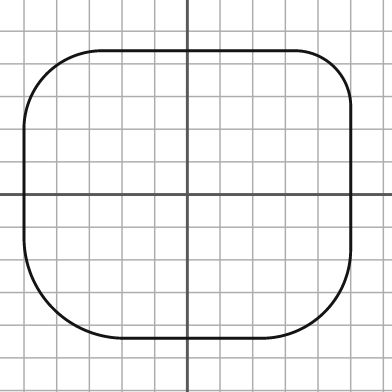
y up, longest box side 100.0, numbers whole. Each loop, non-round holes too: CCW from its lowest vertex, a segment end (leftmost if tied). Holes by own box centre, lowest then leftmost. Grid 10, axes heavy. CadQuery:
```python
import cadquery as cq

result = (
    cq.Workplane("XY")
    .moveTo(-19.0, -44.0)
    .lineTo(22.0, -44.0)
    .threePointArc((42.0, -36.0), (50.0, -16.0))
    .lineTo(50.0, 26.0)
    .threePointArc((45.0, 39.0), (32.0, 44.0))
    .lineTo(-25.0, 44.0)
    .threePointArc((-43.0, 37.0), (-50.0, 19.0))
    .lineTo(-50.0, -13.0)
    .threePointArc((-41.0, -35.0), (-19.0, -44.0))
    .close()
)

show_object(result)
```